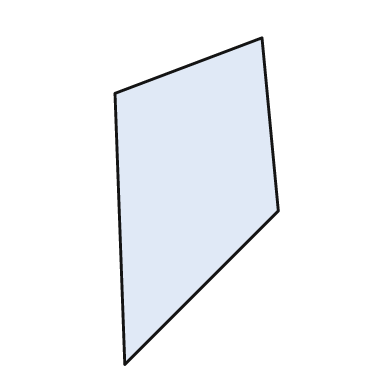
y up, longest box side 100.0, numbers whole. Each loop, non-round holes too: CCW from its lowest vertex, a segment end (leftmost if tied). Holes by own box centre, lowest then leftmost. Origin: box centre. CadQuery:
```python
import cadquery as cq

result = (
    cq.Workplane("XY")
    .moveTo(-22.0, -50.0)
    .lineTo(25.0, -3.0)
    .lineTo(20.0, 50.0)
    .lineTo(-25.0, 33.0)
    .close()
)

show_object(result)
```